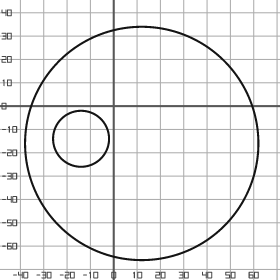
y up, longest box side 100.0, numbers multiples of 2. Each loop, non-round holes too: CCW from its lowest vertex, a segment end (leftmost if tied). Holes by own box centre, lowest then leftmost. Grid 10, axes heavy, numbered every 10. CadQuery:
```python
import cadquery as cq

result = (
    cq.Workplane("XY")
    .moveTo(12.0, -16.0)
    .circle(50.0)
    .moveTo(-14.0, -14.0)
    .circle(12.0)
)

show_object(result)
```